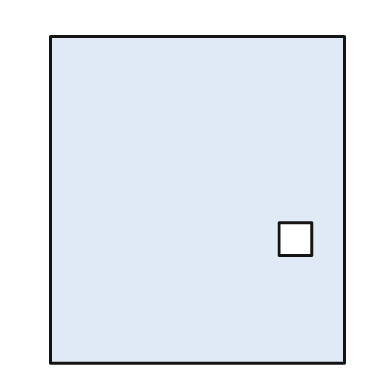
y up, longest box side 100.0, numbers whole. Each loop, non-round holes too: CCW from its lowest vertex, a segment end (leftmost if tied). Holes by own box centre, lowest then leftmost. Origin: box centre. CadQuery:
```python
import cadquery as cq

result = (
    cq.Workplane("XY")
    .moveTo(-45.0, -50.0)
    .lineTo(45.0, -50.0)
    .lineTo(45.0, 50.0)
    .lineTo(-45.0, 50.0)
    .close()
    .moveTo(25.0, -17.0)
    .lineTo(35.0, -17.0)
    .lineTo(35.0, -7.0)
    .lineTo(25.0, -7.0)
    .close()
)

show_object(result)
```